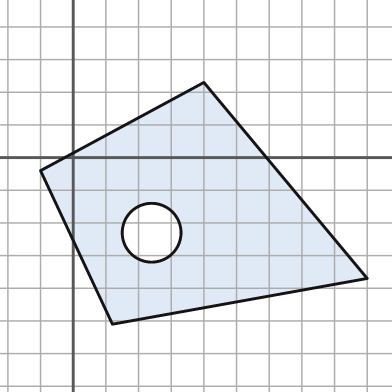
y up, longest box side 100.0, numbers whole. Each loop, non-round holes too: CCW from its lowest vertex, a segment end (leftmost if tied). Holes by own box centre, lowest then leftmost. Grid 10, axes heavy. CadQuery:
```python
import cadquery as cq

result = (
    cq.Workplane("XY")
    .moveTo(12.0, -51.0)
    .lineTo(90.0, -37.0)
    .lineTo(40.0, 23.0)
    .lineTo(-10.0, -4.0)
    .close()
    .moveTo(24.0, -23.0)
    .circle(9.0)
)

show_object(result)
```